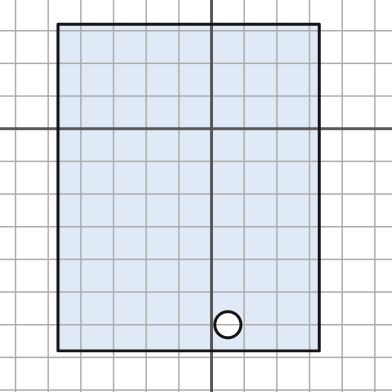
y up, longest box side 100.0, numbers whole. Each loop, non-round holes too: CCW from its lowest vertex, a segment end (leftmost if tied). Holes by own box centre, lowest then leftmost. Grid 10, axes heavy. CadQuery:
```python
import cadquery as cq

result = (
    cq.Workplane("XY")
    .moveTo(-47.0, -68.0)
    .lineTo(33.0, -68.0)
    .lineTo(33.0, 32.0)
    .lineTo(-47.0, 32.0)
    .close()
    .moveTo(5.0, -60.0)
    .circle(4.0)
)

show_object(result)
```